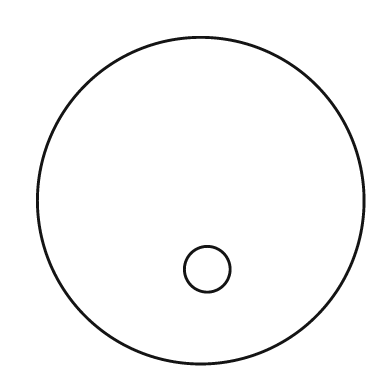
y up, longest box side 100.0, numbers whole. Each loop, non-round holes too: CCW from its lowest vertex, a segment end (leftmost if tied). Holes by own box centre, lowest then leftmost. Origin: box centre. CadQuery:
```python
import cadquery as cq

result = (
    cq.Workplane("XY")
    .moveTo(0.0, 0.0)
    .circle(50.0)
    .moveTo(2.0, -21.0)
    .circle(7.0)
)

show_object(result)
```